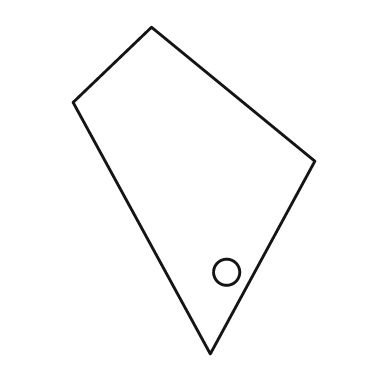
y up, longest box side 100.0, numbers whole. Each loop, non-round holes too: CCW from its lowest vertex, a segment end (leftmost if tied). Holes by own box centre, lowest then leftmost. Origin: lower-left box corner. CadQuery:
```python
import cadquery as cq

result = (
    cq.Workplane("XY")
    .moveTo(42.0, 0.0)
    .lineTo(74.0, 59.0)
    .lineTo(24.0, 100.0)
    .lineTo(0.0, 77.0)
    .close()
    .moveTo(47.0, 25.0)
    .circle(4.0)
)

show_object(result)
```